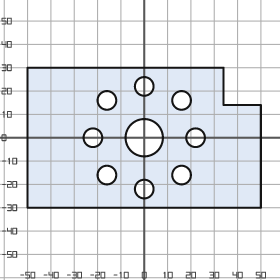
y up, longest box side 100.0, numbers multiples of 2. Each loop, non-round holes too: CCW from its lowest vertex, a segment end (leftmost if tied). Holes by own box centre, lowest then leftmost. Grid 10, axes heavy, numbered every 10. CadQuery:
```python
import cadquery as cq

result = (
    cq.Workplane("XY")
    .moveTo(-50.0, -30.0)
    .lineTo(50.0, -30.0)
    .lineTo(50.0, 14.0)
    .lineTo(34.0, 14.0)
    .lineTo(34.0, 30.0)
    .lineTo(-50.0, 30.0)
    .close()
    .moveTo(0.0, -22.0)
    .circle(4.0)
    .moveTo(-16.0, -16.0)
    .circle(4.0)
    .moveTo(16.0, -16.0)
    .circle(4.0)
    .moveTo(-22.0, 0.0)
    .circle(4.0)
    .moveTo(0.0, 0.0)
    .circle(8.0)
    .moveTo(22.0, 0.0)
    .circle(4.0)
    .moveTo(-16.0, 16.0)
    .circle(4.0)
    .moveTo(16.0, 16.0)
    .circle(4.0)
    .moveTo(0.0, 22.0)
    .circle(4.0)
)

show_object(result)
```